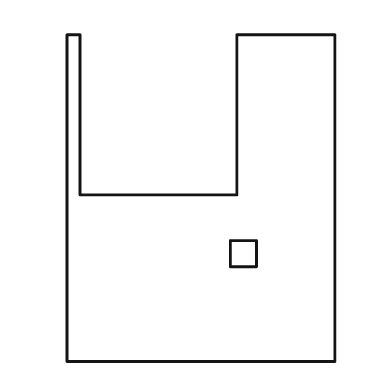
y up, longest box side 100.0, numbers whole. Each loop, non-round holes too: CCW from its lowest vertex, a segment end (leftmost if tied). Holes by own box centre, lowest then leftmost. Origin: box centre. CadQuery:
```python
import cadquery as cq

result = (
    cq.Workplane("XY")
    .moveTo(-41.0, -50.0)
    .lineTo(41.0, -50.0)
    .lineTo(41.0, 50.0)
    .lineTo(11.0, 50.0)
    .lineTo(11.0, 1.0)
    .lineTo(-37.0, 1.0)
    .lineTo(-37.0, 50.0)
    .lineTo(-41.0, 50.0)
    .close()
    .moveTo(9.0, -21.0)
    .lineTo(17.0, -21.0)
    .lineTo(17.0, -13.0)
    .lineTo(9.0, -13.0)
    .close()
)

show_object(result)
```